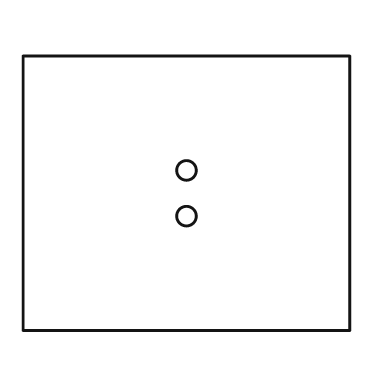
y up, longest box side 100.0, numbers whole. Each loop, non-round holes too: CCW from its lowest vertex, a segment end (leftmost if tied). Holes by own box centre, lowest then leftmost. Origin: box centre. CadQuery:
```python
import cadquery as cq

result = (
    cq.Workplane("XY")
    .moveTo(-50.0, -42.0)
    .lineTo(50.0, -42.0)
    .lineTo(50.0, 42.0)
    .lineTo(-50.0, 42.0)
    .close()
    .moveTo(0.0, -7.0)
    .circle(3.0)
    .moveTo(0.0, 7.0)
    .circle(3.0)
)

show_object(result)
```